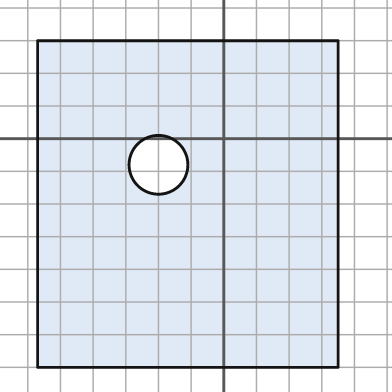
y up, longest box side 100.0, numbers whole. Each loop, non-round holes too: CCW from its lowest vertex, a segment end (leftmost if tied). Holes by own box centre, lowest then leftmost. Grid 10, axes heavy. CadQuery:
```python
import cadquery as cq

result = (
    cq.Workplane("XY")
    .moveTo(-57.0, -70.0)
    .lineTo(35.0, -70.0)
    .lineTo(35.0, 30.0)
    .lineTo(-57.0, 30.0)
    .close()
    .moveTo(-20.0, -8.0)
    .circle(9.0)
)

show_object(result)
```